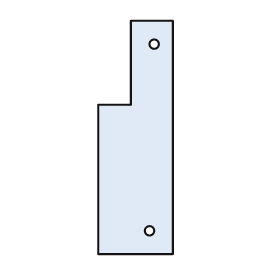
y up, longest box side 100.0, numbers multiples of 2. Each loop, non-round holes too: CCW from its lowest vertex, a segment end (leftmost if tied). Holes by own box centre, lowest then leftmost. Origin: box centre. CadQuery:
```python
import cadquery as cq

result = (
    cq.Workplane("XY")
    .moveTo(-16.0, -50.0)
    .lineTo(16.0, -50.0)
    .lineTo(16.0, 50.0)
    .lineTo(-2.0, 50.0)
    .lineTo(-2.0, 14.0)
    .lineTo(-16.0, 14.0)
    .close()
    .moveTo(6.0, -40.0)
    .circle(2.0)
    .moveTo(8.0, 40.0)
    .circle(2.0)
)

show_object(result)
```